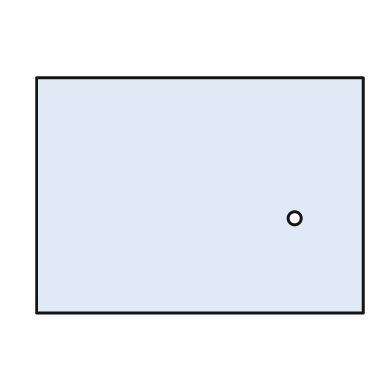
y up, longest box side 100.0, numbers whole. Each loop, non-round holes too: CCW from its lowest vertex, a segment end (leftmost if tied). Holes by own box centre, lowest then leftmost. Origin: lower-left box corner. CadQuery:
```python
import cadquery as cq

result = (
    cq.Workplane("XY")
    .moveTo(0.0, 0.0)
    .lineTo(100.0, 0.0)
    .lineTo(100.0, 72.0)
    .lineTo(0.0, 72.0)
    .close()
    .moveTo(79.0, 29.0)
    .circle(2.0)
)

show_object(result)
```